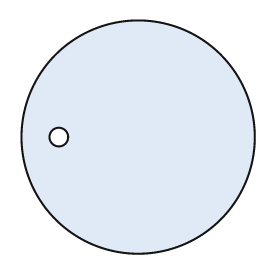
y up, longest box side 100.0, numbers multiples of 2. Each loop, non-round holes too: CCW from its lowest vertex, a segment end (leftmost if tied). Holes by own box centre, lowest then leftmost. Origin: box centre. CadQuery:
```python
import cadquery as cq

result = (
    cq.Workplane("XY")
    .moveTo(0.0, 0.0)
    .circle(50.0)
    .moveTo(-34.0, 0.0)
    .circle(4.0)
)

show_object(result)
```